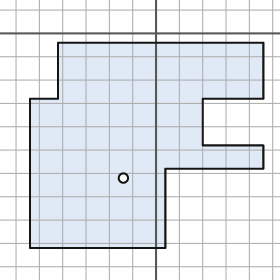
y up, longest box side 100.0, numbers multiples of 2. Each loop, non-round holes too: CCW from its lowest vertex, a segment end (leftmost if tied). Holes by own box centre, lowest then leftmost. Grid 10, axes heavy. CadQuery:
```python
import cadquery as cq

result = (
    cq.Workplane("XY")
    .moveTo(-54.0, -92.0)
    .lineTo(4.0, -92.0)
    .lineTo(4.0, -58.0)
    .lineTo(46.0, -58.0)
    .lineTo(46.0, -48.0)
    .lineTo(20.0, -48.0)
    .lineTo(20.0, -28.0)
    .lineTo(46.0, -28.0)
    .lineTo(46.0, -4.0)
    .lineTo(-42.0, -4.0)
    .lineTo(-42.0, -28.0)
    .lineTo(-54.0, -28.0)
    .close()
    .moveTo(-14.0, -62.0)
    .circle(2.0)
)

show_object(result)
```